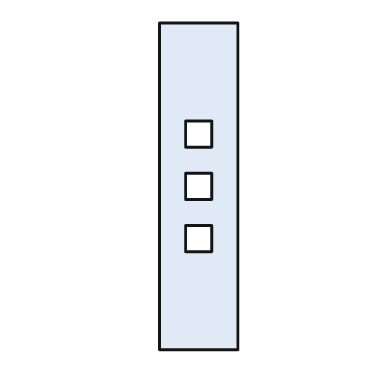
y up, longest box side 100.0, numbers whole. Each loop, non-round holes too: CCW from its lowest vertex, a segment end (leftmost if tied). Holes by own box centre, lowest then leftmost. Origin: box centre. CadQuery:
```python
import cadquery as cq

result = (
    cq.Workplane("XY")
    .moveTo(-12.0, -50.0)
    .lineTo(12.0, -50.0)
    .lineTo(12.0, 50.0)
    .lineTo(-12.0, 50.0)
    .close()
    .moveTo(-4.0, -20.0)
    .lineTo(4.0, -20.0)
    .lineTo(4.0, -12.0)
    .lineTo(-4.0, -12.0)
    .close()
    .moveTo(-4.0, -4.0)
    .lineTo(4.0, -4.0)
    .lineTo(4.0, 4.0)
    .lineTo(-4.0, 4.0)
    .close()
    .moveTo(-4.0, 12.0)
    .lineTo(4.0, 12.0)
    .lineTo(4.0, 20.0)
    .lineTo(-4.0, 20.0)
    .close()
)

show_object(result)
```